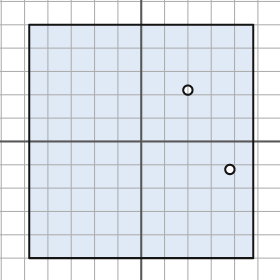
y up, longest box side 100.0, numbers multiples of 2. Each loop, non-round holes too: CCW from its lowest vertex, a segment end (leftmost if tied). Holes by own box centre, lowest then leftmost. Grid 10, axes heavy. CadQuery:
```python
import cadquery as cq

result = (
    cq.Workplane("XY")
    .moveTo(-48.0, -50.0)
    .lineTo(48.0, -50.0)
    .lineTo(48.0, 50.0)
    .lineTo(-48.0, 50.0)
    .close()
    .moveTo(38.0, -12.0)
    .circle(2.0)
    .moveTo(20.0, 22.0)
    .circle(2.0)
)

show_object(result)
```